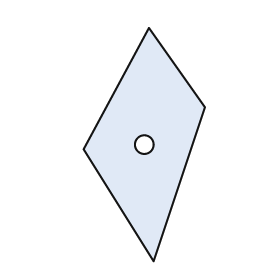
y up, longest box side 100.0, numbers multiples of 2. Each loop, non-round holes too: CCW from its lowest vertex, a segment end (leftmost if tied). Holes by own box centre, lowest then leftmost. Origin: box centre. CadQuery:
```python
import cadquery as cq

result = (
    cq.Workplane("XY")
    .moveTo(4.0, -50.0)
    .lineTo(26.0, 16.0)
    .lineTo(2.0, 50.0)
    .lineTo(-26.0, -2.0)
    .close()
    .moveTo(0.0, 0.0)
    .circle(4.0)
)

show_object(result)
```